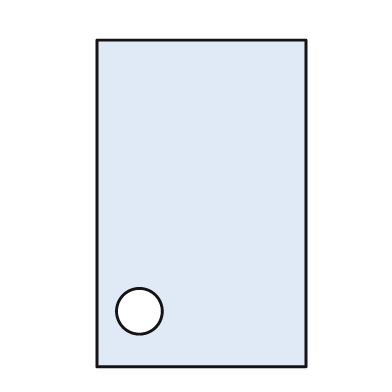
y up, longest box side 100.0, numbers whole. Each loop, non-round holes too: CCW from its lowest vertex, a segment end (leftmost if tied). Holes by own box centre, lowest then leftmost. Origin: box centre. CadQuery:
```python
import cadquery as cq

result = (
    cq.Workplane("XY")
    .moveTo(-32.0, -50.0)
    .lineTo(32.0, -50.0)
    .lineTo(32.0, 50.0)
    .lineTo(-32.0, 50.0)
    .close()
    .moveTo(-19.0, -33.0)
    .circle(7.0)
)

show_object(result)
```